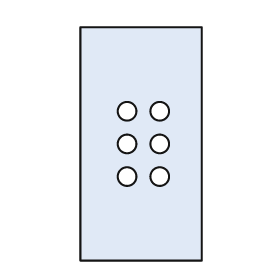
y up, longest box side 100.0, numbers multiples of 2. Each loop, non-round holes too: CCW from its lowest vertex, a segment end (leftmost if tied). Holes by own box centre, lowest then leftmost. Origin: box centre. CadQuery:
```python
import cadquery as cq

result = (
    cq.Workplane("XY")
    .moveTo(-26.0, -50.0)
    .lineTo(26.0, -50.0)
    .lineTo(26.0, 50.0)
    .lineTo(-26.0, 50.0)
    .close()
    .moveTo(-6.0, -14.0)
    .circle(4.0)
    .moveTo(8.0, -14.0)
    .circle(4.0)
    .moveTo(-6.0, 0.0)
    .circle(4.0)
    .moveTo(8.0, 0.0)
    .circle(4.0)
    .moveTo(-6.0, 14.0)
    .circle(4.0)
    .moveTo(8.0, 14.0)
    .circle(4.0)
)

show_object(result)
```